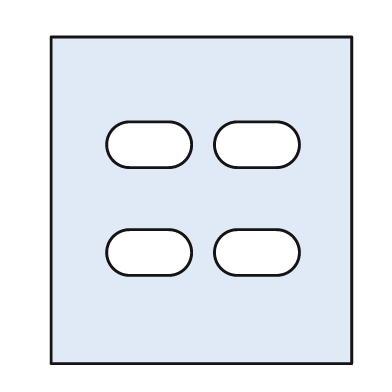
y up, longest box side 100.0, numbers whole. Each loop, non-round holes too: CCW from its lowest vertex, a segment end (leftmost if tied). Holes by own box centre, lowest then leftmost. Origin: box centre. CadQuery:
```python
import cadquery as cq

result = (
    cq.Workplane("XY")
    .moveTo(-46.0, -50.0)
    .lineTo(46.0, -50.0)
    .lineTo(46.0, 50.0)
    .lineTo(-46.0, 50.0)
    .close()
    .moveTo(-22.0, -23.0)
    .lineTo(-10.0, -23.0)
    .threePointArc((-3.0, -16.0), (-10.0, -9.0))
    .lineTo(-22.0, -9.0)
    .threePointArc((-29.0, -16.0), (-22.0, -23.0))
    .close()
    .moveTo(11.0, -23.0)
    .lineTo(23.0, -23.0)
    .threePointArc((30.0, -16.0), (23.0, -9.0))
    .lineTo(11.0, -9.0)
    .threePointArc((4.0, -16.0), (11.0, -23.0))
    .close()
    .moveTo(-22.0, 10.0)
    .lineTo(-10.0, 10.0)
    .threePointArc((-3.0, 17.0), (-10.0, 24.0))
    .lineTo(-22.0, 24.0)
    .threePointArc((-29.0, 17.0), (-22.0, 10.0))
    .close()
    .moveTo(11.0, 10.0)
    .lineTo(23.0, 10.0)
    .threePointArc((30.0, 17.0), (23.0, 24.0))
    .lineTo(11.0, 24.0)
    .threePointArc((4.0, 17.0), (11.0, 10.0))
    .close()
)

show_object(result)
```